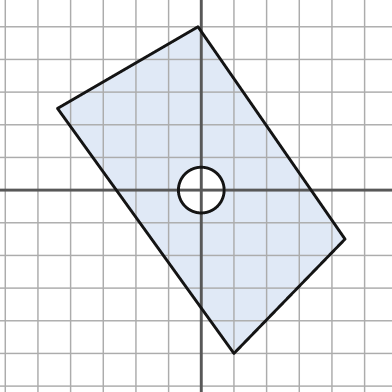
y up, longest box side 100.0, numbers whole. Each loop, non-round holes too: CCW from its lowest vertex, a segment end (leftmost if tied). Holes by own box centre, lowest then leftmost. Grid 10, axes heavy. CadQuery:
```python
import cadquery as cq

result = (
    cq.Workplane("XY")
    .moveTo(10.0, -50.0)
    .lineTo(44.0, -15.0)
    .lineTo(-1.0, 50.0)
    .lineTo(-44.0, 25.0)
    .close()
    .moveTo(0.0, 0.0)
    .circle(7.0)
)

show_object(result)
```